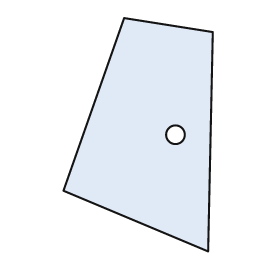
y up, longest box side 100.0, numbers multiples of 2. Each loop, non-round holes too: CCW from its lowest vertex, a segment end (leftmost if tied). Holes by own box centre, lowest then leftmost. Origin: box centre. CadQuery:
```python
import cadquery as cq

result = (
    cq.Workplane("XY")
    .moveTo(30.0, -50.0)
    .lineTo(32.0, 44.0)
    .lineTo(-6.0, 50.0)
    .lineTo(-32.0, -24.0)
    .close()
    .moveTo(16.0, 0.0)
    .circle(4.0)
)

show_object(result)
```